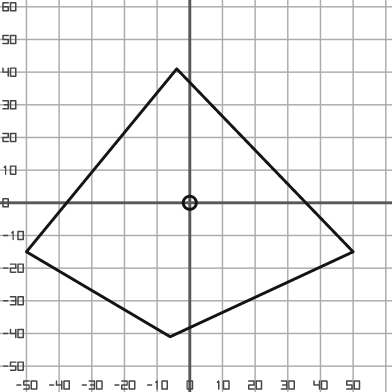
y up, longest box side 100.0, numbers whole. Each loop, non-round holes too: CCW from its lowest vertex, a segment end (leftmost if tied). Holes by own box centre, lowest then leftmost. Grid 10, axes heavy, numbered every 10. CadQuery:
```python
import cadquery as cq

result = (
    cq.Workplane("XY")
    .moveTo(-6.0, -41.0)
    .lineTo(50.0, -15.0)
    .lineTo(-4.0, 41.0)
    .lineTo(-50.0, -15.0)
    .close()
    .moveTo(0.0, 0.0)
    .circle(2.0)
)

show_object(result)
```